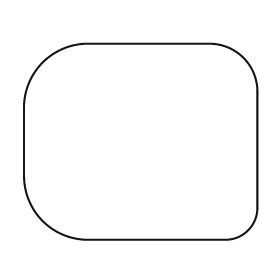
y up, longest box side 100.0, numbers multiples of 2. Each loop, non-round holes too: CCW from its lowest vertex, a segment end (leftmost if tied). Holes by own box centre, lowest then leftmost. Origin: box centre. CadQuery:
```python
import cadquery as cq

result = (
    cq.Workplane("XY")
    .moveTo(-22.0, -42.0)
    .lineTo(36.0, -42.0)
    .threePointArc((46.0, -38.0), (50.0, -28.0))
    .lineTo(50.0, 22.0)
    .threePointArc((44.0, 36.0), (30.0, 42.0))
    .lineTo(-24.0, 42.0)
    .threePointArc((-42.0, 34.0), (-50.0, 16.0))
    .lineTo(-50.0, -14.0)
    .threePointArc((-42.0, -34.0), (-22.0, -42.0))
    .close()
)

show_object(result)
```